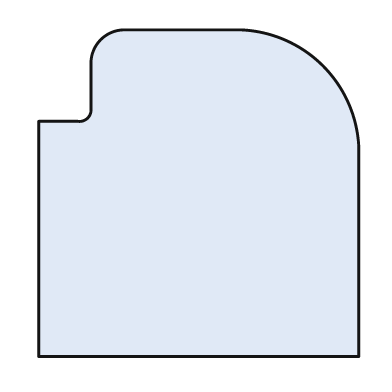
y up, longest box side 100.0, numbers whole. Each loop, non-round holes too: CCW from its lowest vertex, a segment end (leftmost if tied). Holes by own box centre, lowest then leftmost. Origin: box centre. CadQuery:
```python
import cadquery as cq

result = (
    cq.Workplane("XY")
    .moveTo(-49.0, -50.0)
    .lineTo(49.0, -50.0)
    .lineTo(49.0, 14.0)
    .threePointArc((38.0, 39.0), (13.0, 50.0))
    .lineTo(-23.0, 50.0)
    .threePointArc((-30.0, 47.0), (-33.0, 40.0))
    .lineTo(-33.0, 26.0)
    .threePointArc((-34.0, 23.0), (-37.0, 22.0))
    .lineTo(-49.0, 22.0)
    .close()
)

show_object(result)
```